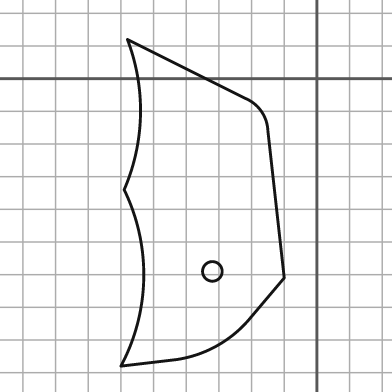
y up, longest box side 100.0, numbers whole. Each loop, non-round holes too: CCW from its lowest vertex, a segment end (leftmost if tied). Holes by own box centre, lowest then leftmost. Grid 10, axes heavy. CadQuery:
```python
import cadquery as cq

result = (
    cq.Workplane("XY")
    .moveTo(-60.0, -88.0)
    .lineTo(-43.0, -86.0)
    .threePointArc((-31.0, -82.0), (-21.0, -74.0))
    .lineTo(-10.0, -61.0)
    .lineTo(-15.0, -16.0)
    .threePointArc((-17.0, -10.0), (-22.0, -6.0))
    .lineTo(-58.0, 12.0)
    .threePointArc((-54.0, -11.0), (-59.0, -34.0))
    .threePointArc((-53.0, -61.0), (-60.0, -88.0))
    .close()
    .moveTo(-32.0, -59.0)
    .circle(3.0)
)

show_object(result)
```